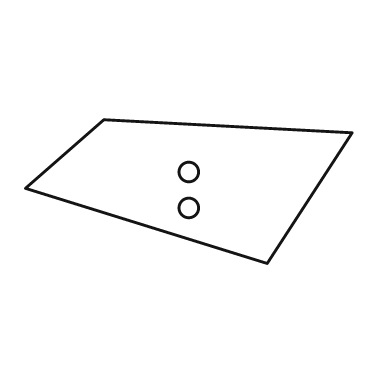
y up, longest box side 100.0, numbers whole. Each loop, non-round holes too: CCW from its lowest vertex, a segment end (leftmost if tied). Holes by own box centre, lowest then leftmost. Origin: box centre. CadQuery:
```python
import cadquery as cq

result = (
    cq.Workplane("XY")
    .moveTo(24.0, -22.0)
    .lineTo(50.0, 18.0)
    .lineTo(-26.0, 22.0)
    .lineTo(-50.0, 1.0)
    .close()
    .moveTo(0.0, -5.0)
    .circle(3.0)
    .moveTo(0.0, 6.0)
    .circle(3.0)
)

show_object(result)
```